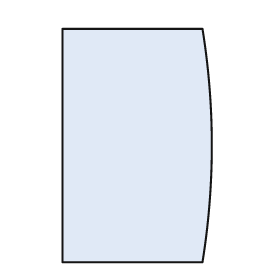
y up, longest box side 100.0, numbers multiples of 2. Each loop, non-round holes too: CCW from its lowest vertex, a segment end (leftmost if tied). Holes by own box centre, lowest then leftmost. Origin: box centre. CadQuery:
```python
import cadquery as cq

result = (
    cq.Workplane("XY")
    .moveTo(-32.0, -50.0)
    .lineTo(28.0, -50.0)
    .threePointArc((32.0, 0.0), (28.0, 50.0))
    .lineTo(-32.0, 50.0)
    .close()
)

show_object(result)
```